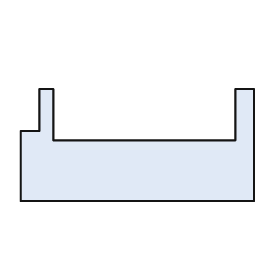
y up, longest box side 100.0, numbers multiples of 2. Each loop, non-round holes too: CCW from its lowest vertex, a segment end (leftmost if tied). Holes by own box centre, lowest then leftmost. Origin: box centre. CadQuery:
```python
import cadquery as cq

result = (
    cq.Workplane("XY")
    .moveTo(-50.0, -24.0)
    .lineTo(50.0, -24.0)
    .lineTo(50.0, 24.0)
    .lineTo(42.0, 24.0)
    .lineTo(42.0, 2.0)
    .lineTo(-36.0, 2.0)
    .lineTo(-36.0, 24.0)
    .lineTo(-42.0, 24.0)
    .lineTo(-42.0, 6.0)
    .lineTo(-50.0, 6.0)
    .close()
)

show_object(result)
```